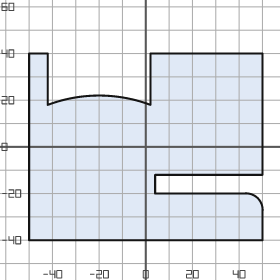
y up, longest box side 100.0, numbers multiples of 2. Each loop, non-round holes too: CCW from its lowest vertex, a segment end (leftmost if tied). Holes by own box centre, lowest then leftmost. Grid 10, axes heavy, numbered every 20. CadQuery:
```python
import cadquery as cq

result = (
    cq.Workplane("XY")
    .moveTo(-50.0, -40.0)
    .lineTo(50.0, -40.0)
    .lineTo(50.0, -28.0)
    .threePointArc((48.0, -22.0), (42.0, -20.0))
    .lineTo(4.0, -20.0)
    .lineTo(4.0, -12.0)
    .lineTo(50.0, -12.0)
    .lineTo(50.0, 40.0)
    .lineTo(2.0, 40.0)
    .lineTo(2.0, 18.0)
    .threePointArc((-20.0, 22.0), (-42.0, 18.0))
    .lineTo(-42.0, 40.0)
    .lineTo(-50.0, 40.0)
    .close()
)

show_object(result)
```